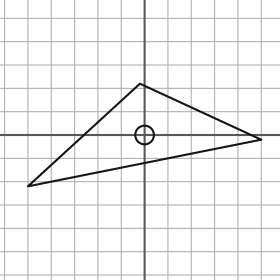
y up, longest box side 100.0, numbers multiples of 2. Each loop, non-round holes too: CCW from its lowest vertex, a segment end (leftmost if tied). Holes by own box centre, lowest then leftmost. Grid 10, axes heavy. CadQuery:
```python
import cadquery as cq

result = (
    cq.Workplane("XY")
    .moveTo(-50.0, -22.0)
    .lineTo(50.0, -2.0)
    .lineTo(-2.0, 22.0)
    .close()
    .moveTo(0.0, 0.0)
    .circle(4.0)
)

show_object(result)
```